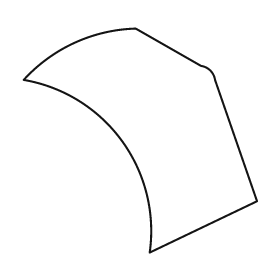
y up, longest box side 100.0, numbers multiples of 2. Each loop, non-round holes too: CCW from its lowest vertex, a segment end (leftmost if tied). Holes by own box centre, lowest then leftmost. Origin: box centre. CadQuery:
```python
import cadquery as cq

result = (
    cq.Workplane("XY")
    .moveTo(4.0, -48.0)
    .lineTo(50.0, -26.0)
    .lineTo(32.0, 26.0)
    .threePointArc((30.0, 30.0), (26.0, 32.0))
    .lineTo(-2.0, 48.0)
    .threePointArc((-28.0, 42.0), (-50.0, 26.0))
    .threePointArc((-8.0, 0.0), (4.0, -48.0))
    .close()
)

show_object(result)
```